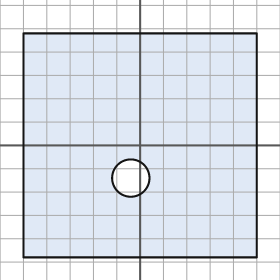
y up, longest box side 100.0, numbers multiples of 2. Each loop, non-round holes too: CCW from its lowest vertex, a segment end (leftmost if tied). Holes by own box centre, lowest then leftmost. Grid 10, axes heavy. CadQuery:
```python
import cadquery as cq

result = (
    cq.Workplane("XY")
    .moveTo(-50.0, -48.0)
    .lineTo(50.0, -48.0)
    .lineTo(50.0, 48.0)
    .lineTo(-50.0, 48.0)
    .close()
    .moveTo(-4.0, -14.0)
    .circle(8.0)
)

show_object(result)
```